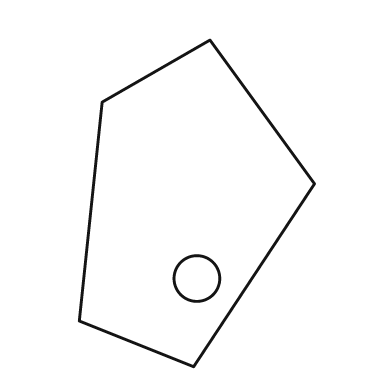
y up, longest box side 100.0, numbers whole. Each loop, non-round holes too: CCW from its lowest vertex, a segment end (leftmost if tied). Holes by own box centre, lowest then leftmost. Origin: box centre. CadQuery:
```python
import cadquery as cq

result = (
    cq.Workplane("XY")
    .moveTo(-1.0, -50.0)
    .lineTo(36.0, 6.0)
    .lineTo(4.0, 50.0)
    .lineTo(-29.0, 31.0)
    .lineTo(-36.0, -36.0)
    .close()
    .moveTo(0.0, -23.0)
    .circle(7.0)
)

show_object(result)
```